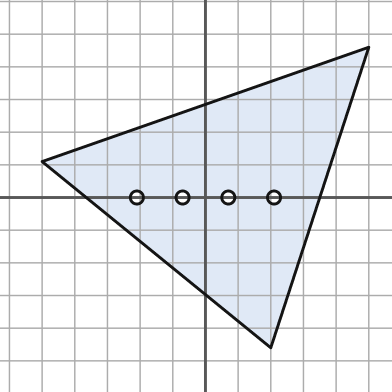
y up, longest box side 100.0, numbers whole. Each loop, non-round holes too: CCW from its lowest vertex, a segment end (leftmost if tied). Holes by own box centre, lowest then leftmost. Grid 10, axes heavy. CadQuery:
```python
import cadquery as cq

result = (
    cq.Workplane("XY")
    .moveTo(20.0, -46.0)
    .lineTo(50.0, 46.0)
    .lineTo(-50.0, 11.0)
    .close()
    .moveTo(-21.0, 0.0)
    .circle(2.0)
    .moveTo(-7.0, 0.0)
    .circle(2.0)
    .moveTo(7.0, 0.0)
    .circle(2.0)
    .moveTo(21.0, 0.0)
    .circle(2.0)
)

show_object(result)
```